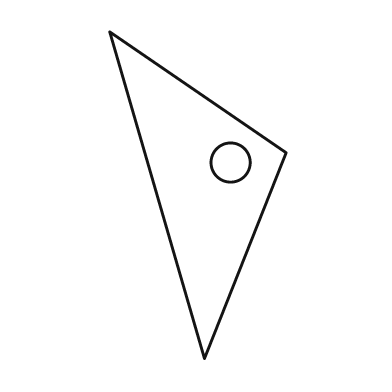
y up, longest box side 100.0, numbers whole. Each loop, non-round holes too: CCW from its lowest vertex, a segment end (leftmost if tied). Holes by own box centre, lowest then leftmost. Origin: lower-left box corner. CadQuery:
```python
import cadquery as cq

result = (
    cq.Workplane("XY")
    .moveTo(29.0, 0.0)
    .lineTo(54.0, 63.0)
    .lineTo(0.0, 100.0)
    .close()
    .moveTo(37.0, 60.0)
    .circle(6.0)
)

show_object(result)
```